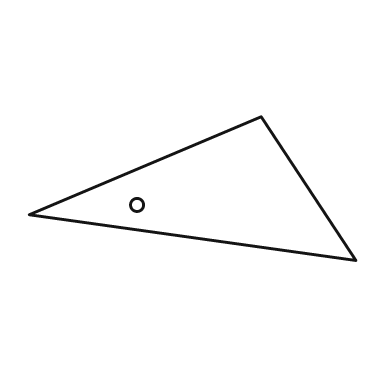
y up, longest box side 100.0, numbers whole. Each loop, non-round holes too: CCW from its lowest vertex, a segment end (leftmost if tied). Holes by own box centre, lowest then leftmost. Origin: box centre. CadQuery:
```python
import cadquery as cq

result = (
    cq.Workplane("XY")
    .moveTo(50.0, -22.0)
    .lineTo(21.0, 22.0)
    .lineTo(-50.0, -8.0)
    .close()
    .moveTo(-17.0, -5.0)
    .circle(2.0)
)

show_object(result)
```